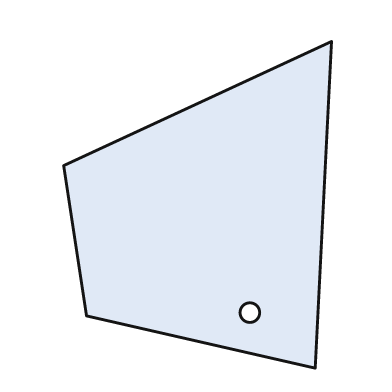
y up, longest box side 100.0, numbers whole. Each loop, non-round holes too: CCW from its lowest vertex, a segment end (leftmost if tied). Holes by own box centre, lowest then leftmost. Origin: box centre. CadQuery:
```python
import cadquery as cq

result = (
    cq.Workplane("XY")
    .moveTo(36.0, -50.0)
    .lineTo(41.0, 50.0)
    .lineTo(-41.0, 12.0)
    .lineTo(-34.0, -34.0)
    .close()
    .moveTo(16.0, -33.0)
    .circle(3.0)
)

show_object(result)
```